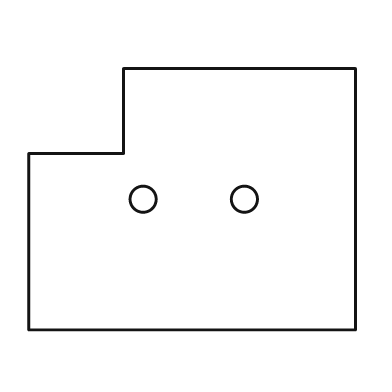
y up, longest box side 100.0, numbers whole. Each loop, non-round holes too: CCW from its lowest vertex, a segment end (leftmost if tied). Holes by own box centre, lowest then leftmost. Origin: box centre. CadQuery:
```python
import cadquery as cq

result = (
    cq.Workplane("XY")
    .moveTo(-50.0, -40.0)
    .lineTo(50.0, -40.0)
    .lineTo(50.0, 40.0)
    .lineTo(-21.0, 40.0)
    .lineTo(-21.0, 14.0)
    .lineTo(-50.0, 14.0)
    .close()
    .moveTo(-15.0, 0.0)
    .circle(4.0)
    .moveTo(16.0, 0.0)
    .circle(4.0)
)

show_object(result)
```